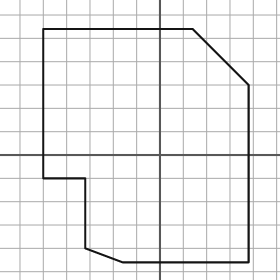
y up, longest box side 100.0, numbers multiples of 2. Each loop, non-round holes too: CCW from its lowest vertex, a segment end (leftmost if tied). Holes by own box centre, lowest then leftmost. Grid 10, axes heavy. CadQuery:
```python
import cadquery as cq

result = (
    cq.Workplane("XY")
    .moveTo(-16.0, -46.0)
    .lineTo(38.0, -46.0)
    .lineTo(38.0, 30.0)
    .lineTo(14.0, 54.0)
    .lineTo(-50.0, 54.0)
    .lineTo(-50.0, -10.0)
    .lineTo(-32.0, -10.0)
    .lineTo(-32.0, -40.0)
    .close()
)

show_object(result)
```